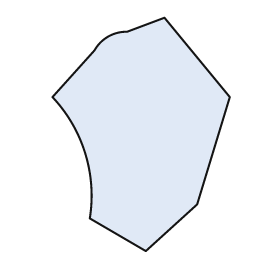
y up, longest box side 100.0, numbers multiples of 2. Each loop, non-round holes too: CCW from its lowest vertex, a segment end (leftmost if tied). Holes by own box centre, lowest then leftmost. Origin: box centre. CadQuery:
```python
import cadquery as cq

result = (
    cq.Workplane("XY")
    .moveTo(2.0, -50.0)
    .lineTo(24.0, -30.0)
    .lineTo(38.0, 16.0)
    .lineTo(10.0, 50.0)
    .lineTo(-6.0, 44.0)
    .threePointArc((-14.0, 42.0), (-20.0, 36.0))
    .lineTo(-38.0, 16.0)
    .threePointArc((-24.0, -8.0), (-22.0, -36.0))
    .close()
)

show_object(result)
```